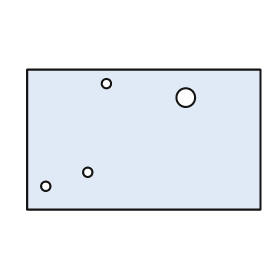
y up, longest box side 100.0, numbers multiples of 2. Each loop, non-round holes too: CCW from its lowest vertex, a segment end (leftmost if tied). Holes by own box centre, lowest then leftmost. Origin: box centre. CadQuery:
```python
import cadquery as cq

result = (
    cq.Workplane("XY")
    .moveTo(-50.0, -30.0)
    .lineTo(50.0, -30.0)
    .lineTo(50.0, 30.0)
    .lineTo(-50.0, 30.0)
    .close()
    .moveTo(-42.0, -20.0)
    .circle(2.0)
    .moveTo(-24.0, -14.0)
    .circle(2.0)
    .moveTo(18.0, 18.0)
    .circle(4.0)
    .moveTo(-16.0, 24.0)
    .circle(2.0)
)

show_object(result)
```